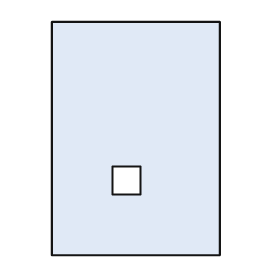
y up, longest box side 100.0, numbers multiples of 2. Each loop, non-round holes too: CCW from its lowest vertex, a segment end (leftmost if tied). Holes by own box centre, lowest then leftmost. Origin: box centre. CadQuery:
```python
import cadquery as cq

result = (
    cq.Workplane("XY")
    .moveTo(-36.0, -50.0)
    .lineTo(36.0, -50.0)
    .lineTo(36.0, 50.0)
    .lineTo(-36.0, 50.0)
    .close()
    .moveTo(-10.0, -24.0)
    .lineTo(2.0, -24.0)
    .lineTo(2.0, -12.0)
    .lineTo(-10.0, -12.0)
    .close()
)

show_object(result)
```